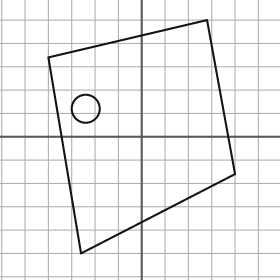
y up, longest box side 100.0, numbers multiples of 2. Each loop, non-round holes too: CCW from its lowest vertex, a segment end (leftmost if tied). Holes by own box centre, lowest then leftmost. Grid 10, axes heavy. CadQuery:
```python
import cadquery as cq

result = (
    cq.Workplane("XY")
    .moveTo(-26.0, -50.0)
    .lineTo(40.0, -16.0)
    .lineTo(28.0, 50.0)
    .lineTo(-40.0, 34.0)
    .close()
    .moveTo(-24.0, 12.0)
    .circle(6.0)
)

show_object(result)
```